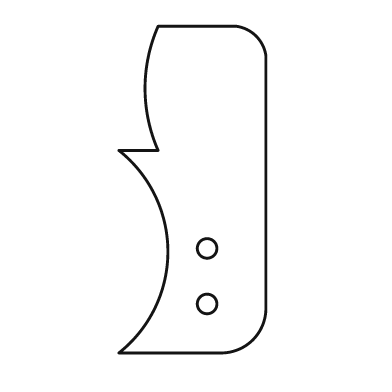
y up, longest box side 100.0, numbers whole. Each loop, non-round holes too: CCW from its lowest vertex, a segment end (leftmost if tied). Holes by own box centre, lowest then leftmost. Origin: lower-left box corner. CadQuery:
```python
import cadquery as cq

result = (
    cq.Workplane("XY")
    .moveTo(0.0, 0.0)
    .lineTo(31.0, 0.0)
    .threePointArc((41.0, 4.0), (45.0, 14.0))
    .lineTo(45.0, 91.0)
    .threePointArc((42.0, 97.0), (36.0, 100.0))
    .lineTo(12.0, 100.0)
    .threePointArc((8.0, 81.0), (12.0, 62.0))
    .lineTo(0.0, 62.0)
    .threePointArc((15.0, 31.0), (0.0, 0.0))
    .close()
    .moveTo(27.0, 15.0)
    .circle(3.0)
    .moveTo(27.0, 32.0)
    .circle(3.0)
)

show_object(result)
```